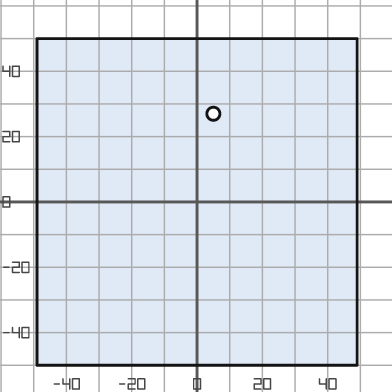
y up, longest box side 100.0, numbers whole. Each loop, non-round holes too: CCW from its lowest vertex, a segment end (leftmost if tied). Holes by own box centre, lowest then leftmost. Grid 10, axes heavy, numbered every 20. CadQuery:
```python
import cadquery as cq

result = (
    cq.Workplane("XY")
    .moveTo(-49.0, -50.0)
    .lineTo(49.0, -50.0)
    .lineTo(49.0, 50.0)
    .lineTo(-49.0, 50.0)
    .close()
    .moveTo(5.0, 27.0)
    .circle(2.0)
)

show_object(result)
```